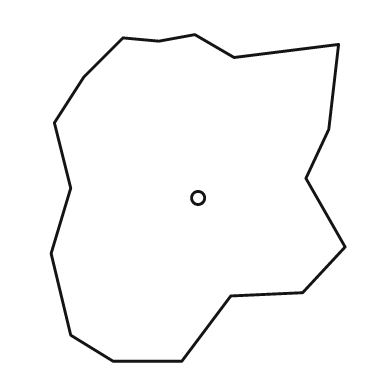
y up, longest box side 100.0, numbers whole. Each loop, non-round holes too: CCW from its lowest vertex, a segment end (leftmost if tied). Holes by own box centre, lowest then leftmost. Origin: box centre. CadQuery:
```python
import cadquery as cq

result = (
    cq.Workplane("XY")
    .moveTo(-26.0, -50.0)
    .lineTo(-5.0, -50.0)
    .lineTo(10.0, -30.0)
    .lineTo(32.0, -29.0)
    .lineTo(45.0, -15.0)
    .lineTo(33.0, 6.0)
    .lineTo(40.0, 21.0)
    .lineTo(43.0, 47.0)
    .lineTo(11.0, 43.0)
    .lineTo(-1.0, 50.0)
    .lineTo(-12.0, 48.0)
    .lineTo(-23.0, 49.0)
    .lineTo(-35.0, 37.0)
    .lineTo(-44.0, 23.0)
    .lineTo(-39.0, 3.0)
    .lineTo(-45.0, -17.0)
    .lineTo(-39.0, -42.0)
    .close()
    .moveTo(0.0, 0.0)
    .circle(2.0)
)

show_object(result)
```